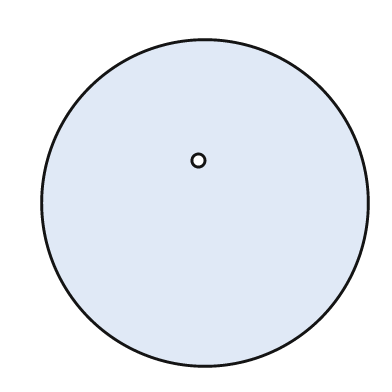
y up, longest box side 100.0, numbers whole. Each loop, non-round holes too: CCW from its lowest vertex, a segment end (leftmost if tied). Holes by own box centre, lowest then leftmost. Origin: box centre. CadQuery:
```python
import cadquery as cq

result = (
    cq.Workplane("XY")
    .moveTo(0.0, 0.0)
    .circle(50.0)
    .moveTo(-2.0, 13.0)
    .circle(2.0)
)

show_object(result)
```